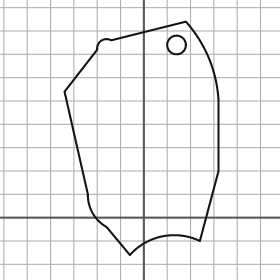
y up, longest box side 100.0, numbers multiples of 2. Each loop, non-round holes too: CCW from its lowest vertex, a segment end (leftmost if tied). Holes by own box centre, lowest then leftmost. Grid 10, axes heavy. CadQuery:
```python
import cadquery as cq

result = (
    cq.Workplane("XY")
    .moveTo(-6.0, -16.0)
    .threePointArc((8.0, -8.0), (24.0, -10.0))
    .lineTo(32.0, 20.0)
    .lineTo(32.0, 50.0)
    .threePointArc((28.0, 68.0), (18.0, 84.0))
    .lineTo(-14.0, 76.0)
    .threePointArc((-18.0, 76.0), (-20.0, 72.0))
    .lineTo(-34.0, 54.0)
    .lineTo(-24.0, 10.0)
    .threePointArc((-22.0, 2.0), (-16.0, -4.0))
    .close()
    .moveTo(14.0, 74.0)
    .circle(4.0)
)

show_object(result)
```